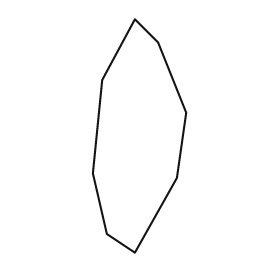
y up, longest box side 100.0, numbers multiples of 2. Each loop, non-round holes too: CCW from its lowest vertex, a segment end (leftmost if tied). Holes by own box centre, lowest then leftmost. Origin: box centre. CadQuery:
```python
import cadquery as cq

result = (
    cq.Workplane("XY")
    .moveTo(-2.0, -50.0)
    .lineTo(16.0, -18.0)
    .lineTo(20.0, 10.0)
    .lineTo(8.0, 40.0)
    .lineTo(-2.0, 50.0)
    .lineTo(-16.0, 24.0)
    .lineTo(-20.0, -16.0)
    .lineTo(-14.0, -42.0)
    .close()
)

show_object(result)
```